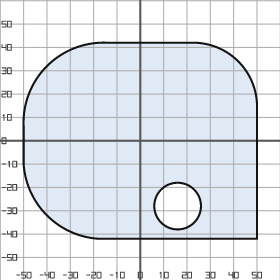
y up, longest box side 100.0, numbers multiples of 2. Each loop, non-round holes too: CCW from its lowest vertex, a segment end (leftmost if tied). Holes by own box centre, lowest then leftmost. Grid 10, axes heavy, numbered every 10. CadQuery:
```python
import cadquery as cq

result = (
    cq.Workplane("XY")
    .moveTo(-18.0, -42.0)
    .lineTo(50.0, -42.0)
    .lineTo(50.0, 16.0)
    .threePointArc((42.0, 34.0), (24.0, 42.0))
    .lineTo(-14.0, 42.0)
    .threePointArc((-40.0, 32.0), (-50.0, 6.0))
    .lineTo(-50.0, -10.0)
    .threePointArc((-40.0, -32.0), (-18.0, -42.0))
    .close()
    .moveTo(16.0, -28.0)
    .circle(10.0)
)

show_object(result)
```